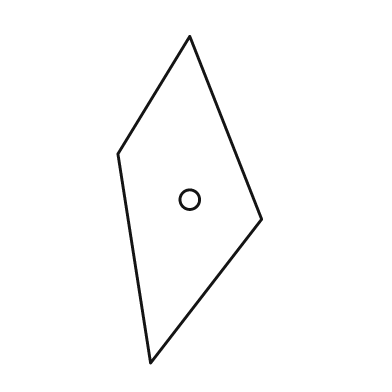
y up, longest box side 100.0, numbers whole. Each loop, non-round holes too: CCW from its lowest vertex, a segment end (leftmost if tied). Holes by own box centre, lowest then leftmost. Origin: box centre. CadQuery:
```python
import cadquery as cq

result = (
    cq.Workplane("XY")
    .moveTo(-12.0, -50.0)
    .lineTo(22.0, -6.0)
    .lineTo(0.0, 50.0)
    .lineTo(-22.0, 14.0)
    .close()
    .moveTo(0.0, 0.0)
    .circle(3.0)
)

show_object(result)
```